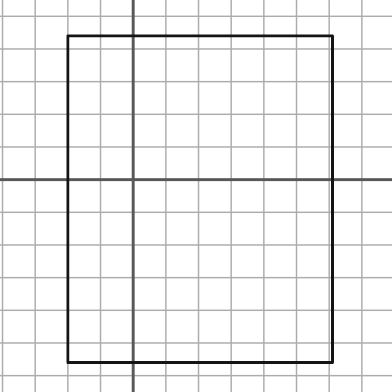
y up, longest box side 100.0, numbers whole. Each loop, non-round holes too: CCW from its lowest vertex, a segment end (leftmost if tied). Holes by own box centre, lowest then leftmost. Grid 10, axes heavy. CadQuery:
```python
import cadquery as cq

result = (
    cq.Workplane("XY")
    .moveTo(-20.0, -56.0)
    .lineTo(61.0, -56.0)
    .lineTo(61.0, 44.0)
    .lineTo(-20.0, 44.0)
    .close()
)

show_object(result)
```